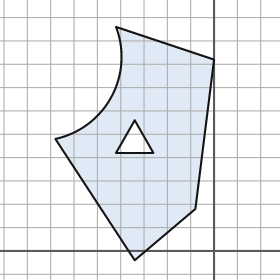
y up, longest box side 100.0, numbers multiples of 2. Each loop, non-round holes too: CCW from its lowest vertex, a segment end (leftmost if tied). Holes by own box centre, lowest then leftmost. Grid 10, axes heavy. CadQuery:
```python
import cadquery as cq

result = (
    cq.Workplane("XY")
    .moveTo(-34.0, -4.0)
    .lineTo(-8.0, 18.0)
    .lineTo(0.0, 82.0)
    .lineTo(-42.0, 96.0)
    .threePointArc((-44.0, 66.0), (-68.0, 48.0))
    .close()
    .moveTo(-42.0, 42.0)
    .lineTo(-26.0, 42.0)
    .lineTo(-34.0, 56.0)
    .close()
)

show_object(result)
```